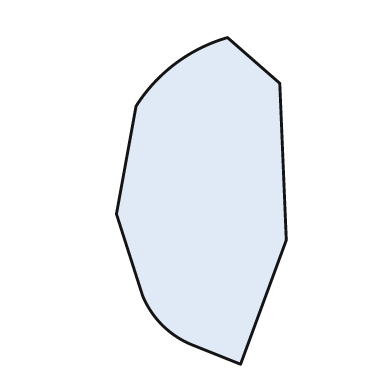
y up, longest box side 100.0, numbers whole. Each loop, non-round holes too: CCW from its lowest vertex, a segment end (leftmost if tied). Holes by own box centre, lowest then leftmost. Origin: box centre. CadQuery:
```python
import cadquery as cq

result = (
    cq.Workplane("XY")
    .moveTo(12.0, -50.0)
    .lineTo(26.0, -12.0)
    .lineTo(24.0, 36.0)
    .lineTo(8.0, 50.0)
    .threePointArc((-8.0, 42.0), (-20.0, 29.0))
    .lineTo(-26.0, -4.0)
    .lineTo(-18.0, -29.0)
    .threePointArc((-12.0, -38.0), (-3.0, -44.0))
    .close()
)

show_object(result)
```